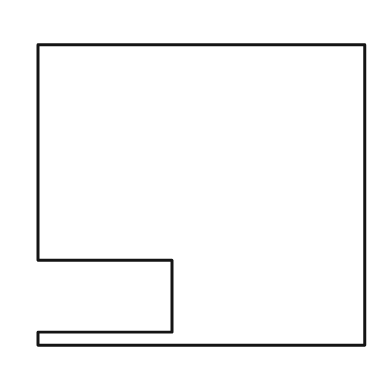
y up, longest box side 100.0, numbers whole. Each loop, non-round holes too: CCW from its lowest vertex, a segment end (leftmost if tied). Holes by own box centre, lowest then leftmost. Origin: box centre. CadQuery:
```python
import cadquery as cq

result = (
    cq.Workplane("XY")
    .moveTo(-50.0, -46.0)
    .lineTo(50.0, -46.0)
    .lineTo(50.0, 46.0)
    .lineTo(-50.0, 46.0)
    .lineTo(-50.0, -20.0)
    .lineTo(-9.0, -20.0)
    .lineTo(-9.0, -42.0)
    .lineTo(-50.0, -42.0)
    .close()
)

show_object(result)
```